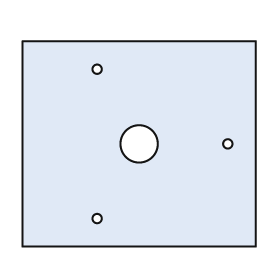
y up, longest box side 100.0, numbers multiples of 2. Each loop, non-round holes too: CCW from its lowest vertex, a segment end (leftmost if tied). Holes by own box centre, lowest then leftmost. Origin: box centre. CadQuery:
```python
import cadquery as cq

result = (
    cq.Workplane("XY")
    .moveTo(-50.0, -44.0)
    .lineTo(50.0, -44.0)
    .lineTo(50.0, 44.0)
    .lineTo(-50.0, 44.0)
    .close()
    .moveTo(-18.0, -32.0)
    .circle(2.0)
    .moveTo(0.0, 0.0)
    .circle(8.0)
    .moveTo(38.0, 0.0)
    .circle(2.0)
    .moveTo(-18.0, 32.0)
    .circle(2.0)
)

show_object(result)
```